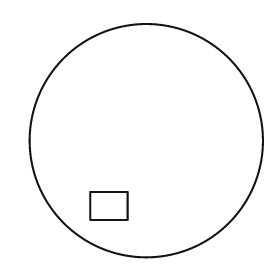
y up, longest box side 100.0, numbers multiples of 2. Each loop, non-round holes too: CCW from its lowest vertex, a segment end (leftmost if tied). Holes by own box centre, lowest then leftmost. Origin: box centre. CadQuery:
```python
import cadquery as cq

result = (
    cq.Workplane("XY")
    .moveTo(0.0, 0.0)
    .circle(50.0)
    .moveTo(-24.0, -34.0)
    .lineTo(-8.0, -34.0)
    .lineTo(-8.0, -22.0)
    .lineTo(-24.0, -22.0)
    .close()
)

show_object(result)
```